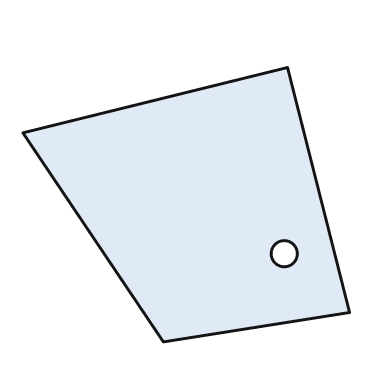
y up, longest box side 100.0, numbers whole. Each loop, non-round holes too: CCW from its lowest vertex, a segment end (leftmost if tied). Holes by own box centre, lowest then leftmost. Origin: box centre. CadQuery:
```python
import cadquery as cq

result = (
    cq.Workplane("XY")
    .moveTo(-7.0, -42.0)
    .lineTo(50.0, -33.0)
    .lineTo(31.0, 42.0)
    .lineTo(-50.0, 22.0)
    .close()
    .moveTo(30.0, -15.0)
    .circle(4.0)
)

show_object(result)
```